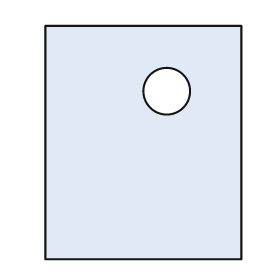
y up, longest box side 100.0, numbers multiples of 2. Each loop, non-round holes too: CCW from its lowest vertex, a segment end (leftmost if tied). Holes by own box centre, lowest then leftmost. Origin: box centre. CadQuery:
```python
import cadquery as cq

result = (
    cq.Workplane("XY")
    .moveTo(-42.0, -50.0)
    .lineTo(42.0, -50.0)
    .lineTo(42.0, 50.0)
    .lineTo(-42.0, 50.0)
    .close()
    .moveTo(10.0, 22.0)
    .circle(10.0)
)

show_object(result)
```